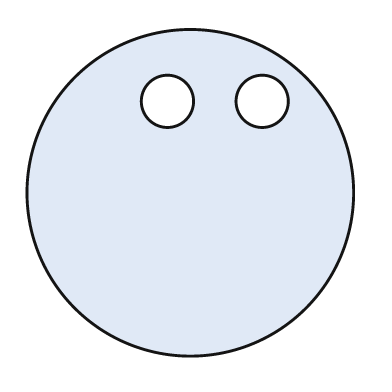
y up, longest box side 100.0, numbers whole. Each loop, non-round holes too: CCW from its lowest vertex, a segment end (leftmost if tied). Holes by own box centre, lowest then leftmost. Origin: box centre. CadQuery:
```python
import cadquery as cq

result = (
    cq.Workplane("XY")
    .moveTo(0.0, 0.0)
    .circle(50.0)
    .moveTo(-7.0, 28.0)
    .circle(8.0)
    .moveTo(22.0, 28.0)
    .circle(8.0)
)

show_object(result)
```